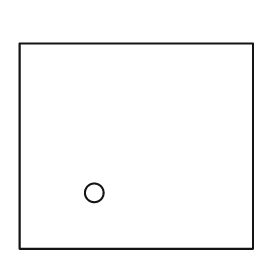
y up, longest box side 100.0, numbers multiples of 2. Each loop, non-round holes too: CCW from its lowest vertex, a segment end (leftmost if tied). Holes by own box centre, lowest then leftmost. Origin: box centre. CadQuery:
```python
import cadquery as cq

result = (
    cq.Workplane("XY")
    .moveTo(-50.0, -44.0)
    .lineTo(50.0, -44.0)
    .lineTo(50.0, 44.0)
    .lineTo(-50.0, 44.0)
    .close()
    .moveTo(-18.0, -20.0)
    .circle(4.0)
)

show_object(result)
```